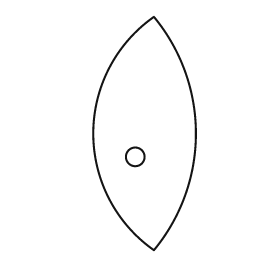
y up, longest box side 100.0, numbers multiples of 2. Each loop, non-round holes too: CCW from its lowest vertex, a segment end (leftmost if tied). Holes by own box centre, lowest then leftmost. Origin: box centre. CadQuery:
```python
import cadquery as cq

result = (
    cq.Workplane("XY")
    .moveTo(4.0, -50.0)
    .threePointArc((22.0, 0.0), (4.0, 50.0))
    .threePointArc((-22.0, 0.0), (4.0, -50.0))
    .close()
    .moveTo(-4.0, -10.0)
    .circle(4.0)
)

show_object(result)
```